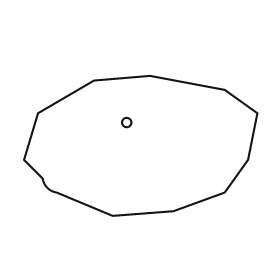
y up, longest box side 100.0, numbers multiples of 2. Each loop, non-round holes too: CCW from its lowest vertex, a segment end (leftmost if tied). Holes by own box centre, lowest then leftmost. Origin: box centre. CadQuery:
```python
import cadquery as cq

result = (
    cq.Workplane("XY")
    .moveTo(-12.0, -30.0)
    .lineTo(14.0, -28.0)
    .lineTo(36.0, -20.0)
    .lineTo(46.0, -6.0)
    .lineTo(50.0, 14.0)
    .lineTo(36.0, 24.0)
    .lineTo(4.0, 30.0)
    .lineTo(-20.0, 28.0)
    .lineTo(-44.0, 14.0)
    .lineTo(-50.0, -6.0)
    .lineTo(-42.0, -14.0)
    .threePointArc((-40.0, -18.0), (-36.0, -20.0))
    .close()
    .moveTo(-6.0, 10.0)
    .circle(2.0)
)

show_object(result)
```